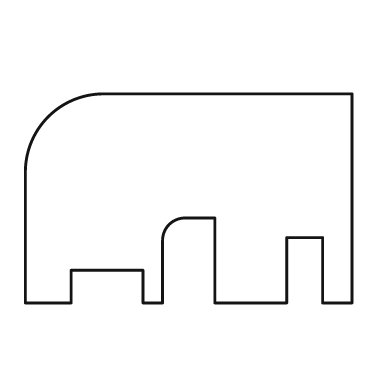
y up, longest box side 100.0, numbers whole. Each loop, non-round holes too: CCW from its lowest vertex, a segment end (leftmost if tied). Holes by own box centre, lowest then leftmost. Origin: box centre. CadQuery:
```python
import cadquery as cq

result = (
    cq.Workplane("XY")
    .moveTo(-50.0, -32.0)
    .lineTo(-36.0, -32.0)
    .lineTo(-36.0, -22.0)
    .lineTo(-14.0, -22.0)
    .lineTo(-14.0, -32.0)
    .lineTo(-8.0, -32.0)
    .lineTo(-8.0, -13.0)
    .threePointArc((-6.0, -8.0), (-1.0, -6.0))
    .lineTo(8.0, -6.0)
    .lineTo(8.0, -32.0)
    .lineTo(30.0, -32.0)
    .lineTo(30.0, -12.0)
    .lineTo(41.0, -12.0)
    .lineTo(41.0, -32.0)
    .lineTo(50.0, -32.0)
    .lineTo(50.0, 32.0)
    .lineTo(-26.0, 32.0)
    .threePointArc((-43.0, 25.0), (-50.0, 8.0))
    .close()
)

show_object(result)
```